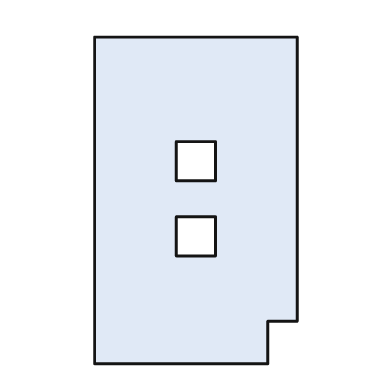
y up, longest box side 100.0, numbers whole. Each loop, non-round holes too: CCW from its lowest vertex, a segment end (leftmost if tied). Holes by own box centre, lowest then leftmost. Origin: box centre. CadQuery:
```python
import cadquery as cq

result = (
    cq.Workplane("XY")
    .moveTo(-31.0, -50.0)
    .lineTo(22.0, -50.0)
    .lineTo(22.0, -37.0)
    .lineTo(31.0, -37.0)
    .lineTo(31.0, 50.0)
    .lineTo(-31.0, 50.0)
    .close()
    .moveTo(-6.0, -17.0)
    .lineTo(6.0, -17.0)
    .lineTo(6.0, -5.0)
    .lineTo(-6.0, -5.0)
    .close()
    .moveTo(-6.0, 6.0)
    .lineTo(6.0, 6.0)
    .lineTo(6.0, 18.0)
    .lineTo(-6.0, 18.0)
    .close()
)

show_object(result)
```